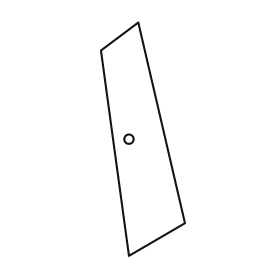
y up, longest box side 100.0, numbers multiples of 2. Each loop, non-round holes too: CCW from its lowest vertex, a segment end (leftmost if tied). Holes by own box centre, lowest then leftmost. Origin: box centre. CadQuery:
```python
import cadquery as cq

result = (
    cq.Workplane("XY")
    .moveTo(-6.0, -50.0)
    .lineTo(18.0, -36.0)
    .lineTo(-2.0, 50.0)
    .lineTo(-18.0, 38.0)
    .close()
    .moveTo(-6.0, 0.0)
    .circle(2.0)
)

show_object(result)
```